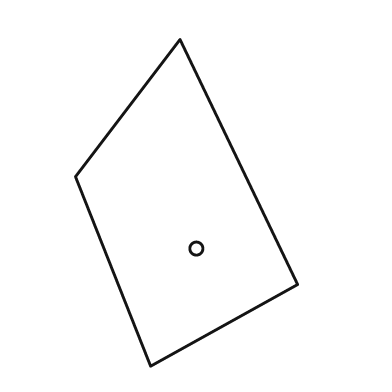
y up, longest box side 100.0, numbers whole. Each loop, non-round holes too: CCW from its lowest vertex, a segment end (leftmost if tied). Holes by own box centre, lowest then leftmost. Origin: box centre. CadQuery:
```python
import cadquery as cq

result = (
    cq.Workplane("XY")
    .moveTo(-11.0, -50.0)
    .lineTo(34.0, -25.0)
    .lineTo(-2.0, 50.0)
    .lineTo(-34.0, 8.0)
    .close()
    .moveTo(3.0, -14.0)
    .circle(2.0)
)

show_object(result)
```